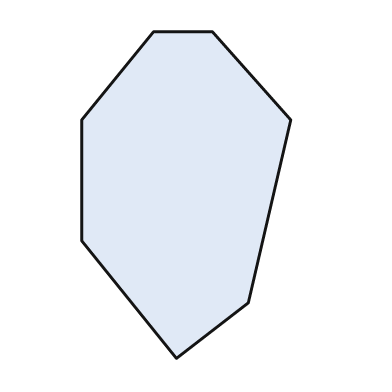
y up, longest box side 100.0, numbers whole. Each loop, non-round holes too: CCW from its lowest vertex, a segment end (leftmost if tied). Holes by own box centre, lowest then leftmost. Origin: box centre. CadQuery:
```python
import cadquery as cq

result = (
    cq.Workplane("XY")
    .moveTo(-3.0, -50.0)
    .lineTo(19.0, -33.0)
    .lineTo(32.0, 23.0)
    .lineTo(8.0, 50.0)
    .lineTo(-10.0, 50.0)
    .lineTo(-32.0, 23.0)
    .lineTo(-32.0, -14.0)
    .close()
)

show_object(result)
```